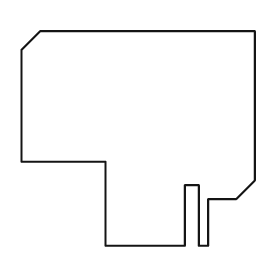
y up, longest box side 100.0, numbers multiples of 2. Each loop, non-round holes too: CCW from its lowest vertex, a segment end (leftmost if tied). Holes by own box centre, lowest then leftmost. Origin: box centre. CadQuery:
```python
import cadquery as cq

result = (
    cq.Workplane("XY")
    .moveTo(-14.0, -46.0)
    .lineTo(20.0, -46.0)
    .lineTo(20.0, -20.0)
    .lineTo(26.0, -20.0)
    .lineTo(26.0, -46.0)
    .lineTo(30.0, -46.0)
    .lineTo(30.0, -26.0)
    .lineTo(42.0, -26.0)
    .lineTo(50.0, -18.0)
    .lineTo(50.0, 46.0)
    .lineTo(-42.0, 46.0)
    .lineTo(-50.0, 38.0)
    .lineTo(-50.0, -10.0)
    .lineTo(-14.0, -10.0)
    .close()
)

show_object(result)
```